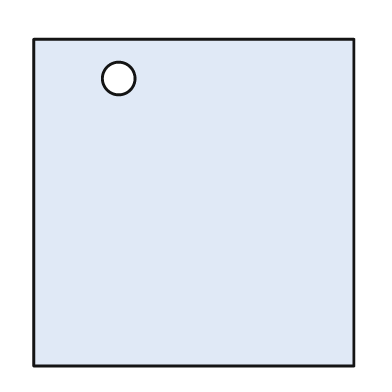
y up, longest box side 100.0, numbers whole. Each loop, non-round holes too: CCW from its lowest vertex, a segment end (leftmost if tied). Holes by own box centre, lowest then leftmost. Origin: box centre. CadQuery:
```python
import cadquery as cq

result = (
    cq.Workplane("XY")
    .moveTo(-49.0, -50.0)
    .lineTo(49.0, -50.0)
    .lineTo(49.0, 50.0)
    .lineTo(-49.0, 50.0)
    .close()
    .moveTo(-23.0, 38.0)
    .circle(5.0)
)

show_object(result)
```